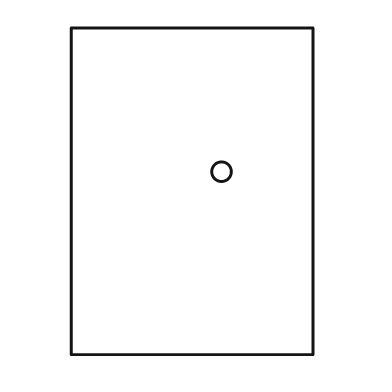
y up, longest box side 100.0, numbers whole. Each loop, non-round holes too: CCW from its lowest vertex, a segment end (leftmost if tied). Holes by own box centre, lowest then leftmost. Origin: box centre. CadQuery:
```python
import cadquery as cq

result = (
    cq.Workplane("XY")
    .moveTo(-37.0, -50.0)
    .lineTo(37.0, -50.0)
    .lineTo(37.0, 50.0)
    .lineTo(-37.0, 50.0)
    .close()
    .moveTo(9.0, 6.0)
    .circle(3.0)
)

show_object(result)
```